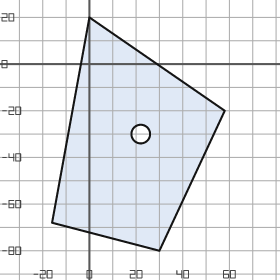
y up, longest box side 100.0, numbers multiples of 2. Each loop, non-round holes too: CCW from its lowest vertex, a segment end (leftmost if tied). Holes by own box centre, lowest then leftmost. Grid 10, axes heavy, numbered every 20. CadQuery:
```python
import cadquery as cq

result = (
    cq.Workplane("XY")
    .moveTo(30.0, -80.0)
    .lineTo(58.0, -20.0)
    .lineTo(0.0, 20.0)
    .lineTo(-16.0, -68.0)
    .close()
    .moveTo(22.0, -30.0)
    .circle(4.0)
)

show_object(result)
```